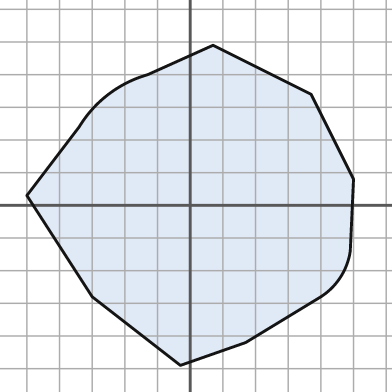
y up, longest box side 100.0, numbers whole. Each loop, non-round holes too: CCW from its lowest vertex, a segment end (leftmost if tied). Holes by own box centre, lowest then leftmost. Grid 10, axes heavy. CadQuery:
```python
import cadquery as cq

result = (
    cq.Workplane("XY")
    .moveTo(-3.0, -49.0)
    .lineTo(17.0, -42.0)
    .lineTo(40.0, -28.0)
    .threePointArc((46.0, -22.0), (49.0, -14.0))
    .lineTo(50.0, 8.0)
    .lineTo(37.0, 34.0)
    .lineTo(7.0, 49.0)
    .lineTo(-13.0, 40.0)
    .threePointArc((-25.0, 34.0), (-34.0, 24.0))
    .lineTo(-50.0, 3.0)
    .lineTo(-30.0, -28.0)
    .close()
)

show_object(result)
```